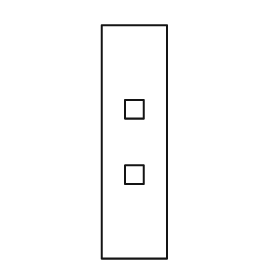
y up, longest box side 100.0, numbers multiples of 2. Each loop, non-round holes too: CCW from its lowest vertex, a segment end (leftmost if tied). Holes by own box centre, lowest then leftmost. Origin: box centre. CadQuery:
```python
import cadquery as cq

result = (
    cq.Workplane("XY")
    .moveTo(-14.0, -50.0)
    .lineTo(14.0, -50.0)
    .lineTo(14.0, 50.0)
    .lineTo(-14.0, 50.0)
    .close()
    .moveTo(-4.0, -18.0)
    .lineTo(4.0, -18.0)
    .lineTo(4.0, -10.0)
    .lineTo(-4.0, -10.0)
    .close()
    .moveTo(-4.0, 10.0)
    .lineTo(4.0, 10.0)
    .lineTo(4.0, 18.0)
    .lineTo(-4.0, 18.0)
    .close()
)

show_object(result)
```